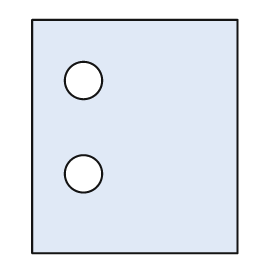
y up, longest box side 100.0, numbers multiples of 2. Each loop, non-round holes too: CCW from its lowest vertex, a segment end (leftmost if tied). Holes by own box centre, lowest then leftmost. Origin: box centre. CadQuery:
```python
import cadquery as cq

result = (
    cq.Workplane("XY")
    .moveTo(-44.0, -50.0)
    .lineTo(44.0, -50.0)
    .lineTo(44.0, 50.0)
    .lineTo(-44.0, 50.0)
    .close()
    .moveTo(-22.0, -16.0)
    .circle(8.0)
    .moveTo(-22.0, 24.0)
    .circle(8.0)
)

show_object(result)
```